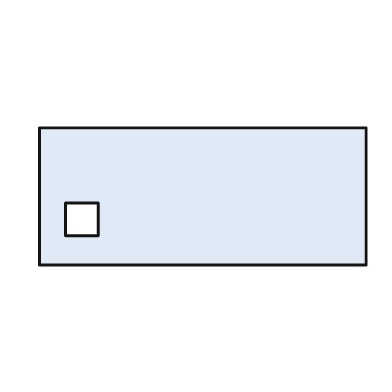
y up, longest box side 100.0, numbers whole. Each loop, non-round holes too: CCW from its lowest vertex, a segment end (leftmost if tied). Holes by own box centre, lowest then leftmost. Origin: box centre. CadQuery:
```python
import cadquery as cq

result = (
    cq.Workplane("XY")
    .moveTo(-50.0, -21.0)
    .lineTo(50.0, -21.0)
    .lineTo(50.0, 21.0)
    .lineTo(-50.0, 21.0)
    .close()
    .moveTo(-42.0, -12.0)
    .lineTo(-32.0, -12.0)
    .lineTo(-32.0, -2.0)
    .lineTo(-42.0, -2.0)
    .close()
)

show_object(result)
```